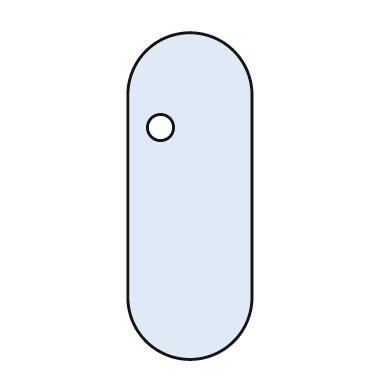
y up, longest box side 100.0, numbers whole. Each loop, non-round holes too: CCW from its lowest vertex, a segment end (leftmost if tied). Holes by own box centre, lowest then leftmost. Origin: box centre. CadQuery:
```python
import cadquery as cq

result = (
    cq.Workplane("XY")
    .moveTo(-19.0, -31.0)
    .threePointArc((0.0, -50.0), (19.0, -31.0))
    .lineTo(19.0, 31.0)
    .threePointArc((0.0, 50.0), (-19.0, 31.0))
    .close()
    .moveTo(-9.0, 21.0)
    .circle(4.0)
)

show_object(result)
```